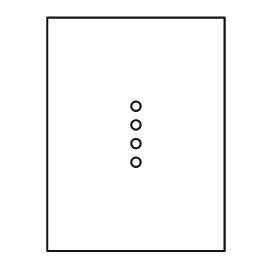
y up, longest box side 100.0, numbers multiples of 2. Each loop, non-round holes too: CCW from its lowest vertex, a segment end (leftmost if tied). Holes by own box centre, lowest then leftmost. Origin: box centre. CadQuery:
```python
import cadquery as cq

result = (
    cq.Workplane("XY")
    .moveTo(-38.0, -50.0)
    .lineTo(38.0, -50.0)
    .lineTo(38.0, 50.0)
    .lineTo(-38.0, 50.0)
    .close()
    .moveTo(0.0, -12.0)
    .circle(2.0)
    .moveTo(0.0, -4.0)
    .circle(2.0)
    .moveTo(0.0, 4.0)
    .circle(2.0)
    .moveTo(0.0, 12.0)
    .circle(2.0)
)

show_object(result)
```